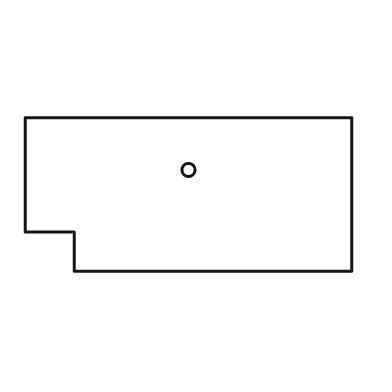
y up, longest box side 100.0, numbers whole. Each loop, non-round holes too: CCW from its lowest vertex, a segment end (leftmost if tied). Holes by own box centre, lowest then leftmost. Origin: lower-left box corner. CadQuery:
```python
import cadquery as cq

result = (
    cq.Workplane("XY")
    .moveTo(15.0, 0.0)
    .lineTo(100.0, 0.0)
    .lineTo(100.0, 47.0)
    .lineTo(0.0, 47.0)
    .lineTo(0.0, 12.0)
    .lineTo(15.0, 12.0)
    .close()
    .moveTo(50.0, 31.0)
    .circle(2.0)
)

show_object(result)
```